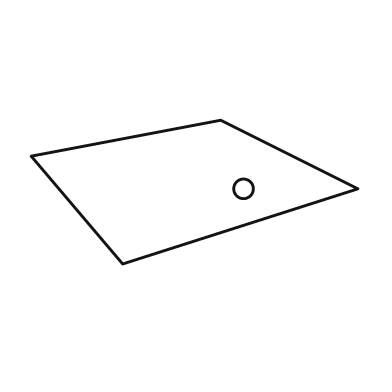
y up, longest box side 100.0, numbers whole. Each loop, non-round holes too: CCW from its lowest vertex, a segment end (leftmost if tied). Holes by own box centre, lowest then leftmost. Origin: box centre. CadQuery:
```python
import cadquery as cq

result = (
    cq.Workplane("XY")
    .moveTo(-22.0, -22.0)
    .lineTo(50.0, 1.0)
    .lineTo(8.0, 22.0)
    .lineTo(-50.0, 11.0)
    .close()
    .moveTo(15.0, 1.0)
    .circle(3.0)
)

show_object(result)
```